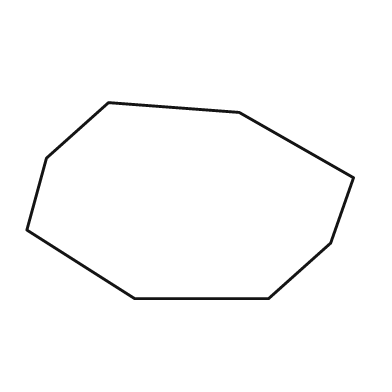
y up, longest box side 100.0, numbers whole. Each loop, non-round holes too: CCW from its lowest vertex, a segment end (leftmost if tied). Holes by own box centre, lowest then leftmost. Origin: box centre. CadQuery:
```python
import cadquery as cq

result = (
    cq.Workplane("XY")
    .moveTo(-17.0, -30.0)
    .lineTo(24.0, -30.0)
    .lineTo(43.0, -13.0)
    .lineTo(50.0, 7.0)
    .lineTo(15.0, 27.0)
    .lineTo(-25.0, 30.0)
    .lineTo(-44.0, 13.0)
    .lineTo(-50.0, -9.0)
    .close()
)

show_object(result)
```